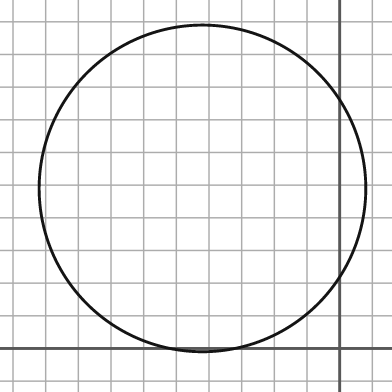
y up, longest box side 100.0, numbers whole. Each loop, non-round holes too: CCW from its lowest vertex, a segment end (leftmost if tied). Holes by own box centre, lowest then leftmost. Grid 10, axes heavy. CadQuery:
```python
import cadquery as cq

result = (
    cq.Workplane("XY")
    .moveTo(-42.0, 49.0)
    .circle(50.0)
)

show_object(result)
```